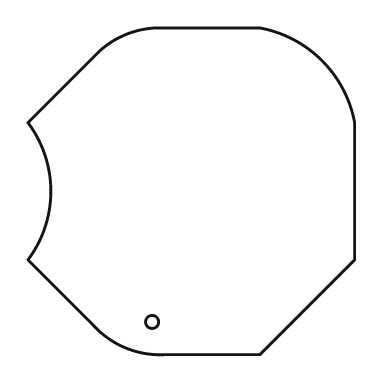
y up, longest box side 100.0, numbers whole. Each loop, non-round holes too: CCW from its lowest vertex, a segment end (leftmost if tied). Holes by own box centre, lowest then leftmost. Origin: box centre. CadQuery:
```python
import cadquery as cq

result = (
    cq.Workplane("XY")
    .moveTo(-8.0, -50.0)
    .lineTo(21.0, -50.0)
    .lineTo(50.0, -21.0)
    .lineTo(50.0, 21.0)
    .threePointArc((40.0, 40.0), (21.0, 50.0))
    .lineTo(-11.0, 50.0)
    .threePointArc((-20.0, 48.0), (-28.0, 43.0))
    .lineTo(-50.0, 21.0)
    .threePointArc((-43.0, 0.0), (-50.0, -21.0))
    .lineTo(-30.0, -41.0)
    .threePointArc((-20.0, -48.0), (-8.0, -50.0))
    .close()
    .moveTo(-12.0, -40.0)
    .circle(2.0)
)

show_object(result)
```